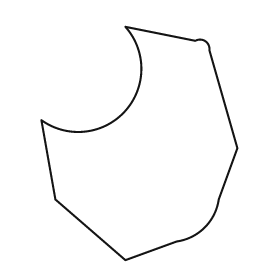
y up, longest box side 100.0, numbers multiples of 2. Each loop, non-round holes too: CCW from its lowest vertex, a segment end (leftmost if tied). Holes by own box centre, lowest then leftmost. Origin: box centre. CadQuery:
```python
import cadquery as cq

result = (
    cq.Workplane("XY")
    .moveTo(-6.0, -50.0)
    .lineTo(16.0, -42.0)
    .threePointArc((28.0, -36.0), (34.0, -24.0))
    .lineTo(42.0, -2.0)
    .lineTo(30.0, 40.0)
    .threePointArc((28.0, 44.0), (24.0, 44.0))
    .lineTo(-6.0, 50.0)
    .threePointArc((-6.0, 14.0), (-42.0, 10.0))
    .lineTo(-36.0, -24.0)
    .close()
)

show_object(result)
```